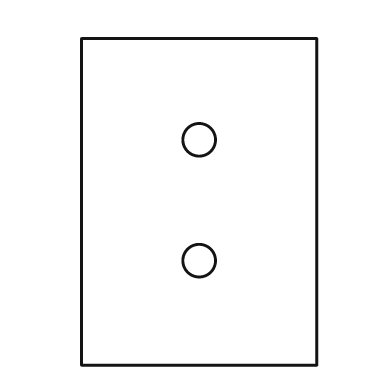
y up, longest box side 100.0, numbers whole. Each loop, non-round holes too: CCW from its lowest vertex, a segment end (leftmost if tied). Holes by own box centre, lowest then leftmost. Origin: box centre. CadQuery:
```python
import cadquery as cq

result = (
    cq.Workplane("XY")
    .moveTo(-36.0, -50.0)
    .lineTo(36.0, -50.0)
    .lineTo(36.0, 50.0)
    .lineTo(-36.0, 50.0)
    .close()
    .moveTo(0.0, -18.0)
    .circle(5.0)
    .moveTo(0.0, 19.0)
    .circle(5.0)
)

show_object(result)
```